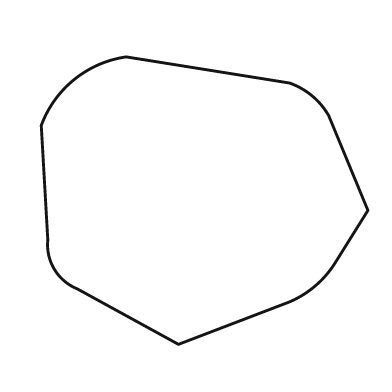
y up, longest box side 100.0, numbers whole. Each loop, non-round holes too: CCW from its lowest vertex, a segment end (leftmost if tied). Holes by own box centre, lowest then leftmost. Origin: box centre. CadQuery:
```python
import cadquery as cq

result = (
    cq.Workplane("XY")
    .moveTo(-8.0, -44.0)
    .lineTo(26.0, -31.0)
    .threePointArc((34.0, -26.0), (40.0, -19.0))
    .lineTo(50.0, -3.0)
    .lineTo(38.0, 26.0)
    .threePointArc((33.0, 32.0), (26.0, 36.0))
    .lineTo(-24.0, 44.0)
    .threePointArc((-40.0, 37.0), (-50.0, 23.0))
    .lineTo(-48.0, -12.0)
    .threePointArc((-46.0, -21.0), (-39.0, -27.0))
    .close()
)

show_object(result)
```